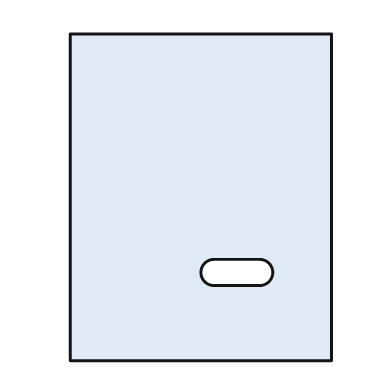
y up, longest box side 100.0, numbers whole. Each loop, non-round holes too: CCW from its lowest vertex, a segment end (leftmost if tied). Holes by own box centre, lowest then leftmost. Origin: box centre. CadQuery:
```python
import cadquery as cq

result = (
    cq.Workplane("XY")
    .moveTo(-40.0, -50.0)
    .lineTo(40.0, -50.0)
    .lineTo(40.0, 50.0)
    .lineTo(-40.0, 50.0)
    .close()
    .moveTo(4.0, -27.0)
    .lineTo(18.0, -27.0)
    .threePointArc((22.0, -23.0), (18.0, -19.0))
    .lineTo(4.0, -19.0)
    .threePointArc((0.0, -23.0), (4.0, -27.0))
    .close()
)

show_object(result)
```